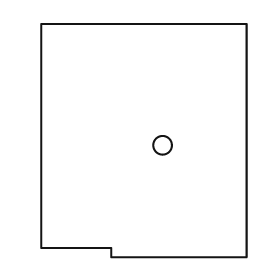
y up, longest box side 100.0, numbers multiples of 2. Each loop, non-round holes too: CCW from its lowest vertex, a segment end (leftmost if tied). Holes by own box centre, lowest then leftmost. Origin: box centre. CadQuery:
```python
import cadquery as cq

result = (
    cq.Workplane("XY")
    .moveTo(-14.0, -50.0)
    .lineTo(44.0, -50.0)
    .lineTo(44.0, 50.0)
    .lineTo(-44.0, 50.0)
    .lineTo(-44.0, -46.0)
    .lineTo(-14.0, -46.0)
    .close()
    .moveTo(8.0, -2.0)
    .circle(4.0)
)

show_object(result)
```